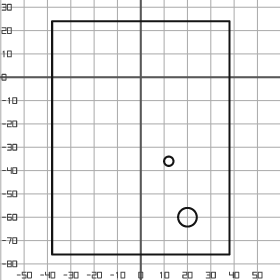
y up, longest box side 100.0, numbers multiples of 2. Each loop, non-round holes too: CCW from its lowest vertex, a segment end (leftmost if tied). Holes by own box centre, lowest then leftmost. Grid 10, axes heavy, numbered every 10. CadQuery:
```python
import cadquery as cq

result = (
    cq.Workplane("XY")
    .moveTo(-38.0, -76.0)
    .lineTo(38.0, -76.0)
    .lineTo(38.0, 24.0)
    .lineTo(-38.0, 24.0)
    .close()
    .moveTo(20.0, -60.0)
    .circle(4.0)
    .moveTo(12.0, -36.0)
    .circle(2.0)
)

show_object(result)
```